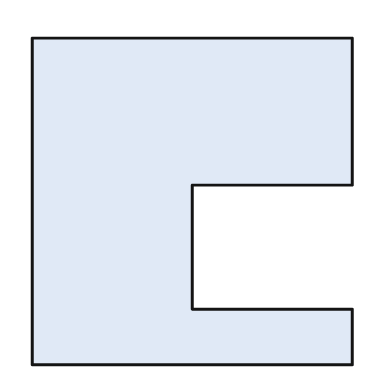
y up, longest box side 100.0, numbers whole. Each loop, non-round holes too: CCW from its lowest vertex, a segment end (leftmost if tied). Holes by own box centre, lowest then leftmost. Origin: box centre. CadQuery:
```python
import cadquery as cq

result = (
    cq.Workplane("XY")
    .moveTo(-49.0, -50.0)
    .lineTo(49.0, -50.0)
    .lineTo(49.0, -33.0)
    .lineTo(0.0, -33.0)
    .lineTo(0.0, 5.0)
    .lineTo(49.0, 5.0)
    .lineTo(49.0, 50.0)
    .lineTo(-49.0, 50.0)
    .close()
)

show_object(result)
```